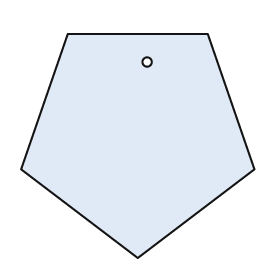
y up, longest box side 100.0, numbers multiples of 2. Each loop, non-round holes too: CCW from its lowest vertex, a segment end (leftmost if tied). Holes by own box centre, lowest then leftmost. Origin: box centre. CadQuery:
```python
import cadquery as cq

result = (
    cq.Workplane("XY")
    .moveTo(0.0, -48.0)
    .lineTo(50.0, -10.0)
    .lineTo(30.0, 48.0)
    .lineTo(-30.0, 48.0)
    .lineTo(-50.0, -10.0)
    .close()
    .moveTo(4.0, 36.0)
    .circle(2.0)
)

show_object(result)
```